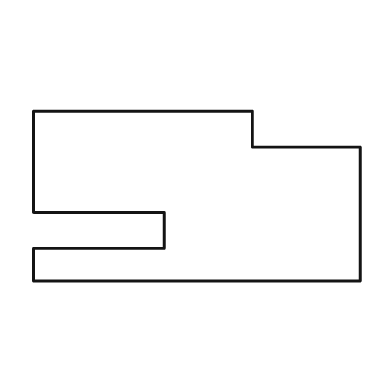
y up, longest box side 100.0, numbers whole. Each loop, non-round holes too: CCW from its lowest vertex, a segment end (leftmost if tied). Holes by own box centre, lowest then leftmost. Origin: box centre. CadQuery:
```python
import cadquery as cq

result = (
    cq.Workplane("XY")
    .moveTo(-50.0, -26.0)
    .lineTo(50.0, -26.0)
    .lineTo(50.0, 15.0)
    .lineTo(17.0, 15.0)
    .lineTo(17.0, 26.0)
    .lineTo(-50.0, 26.0)
    .lineTo(-50.0, -5.0)
    .lineTo(-10.0, -5.0)
    .lineTo(-10.0, -16.0)
    .lineTo(-50.0, -16.0)
    .close()
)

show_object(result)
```